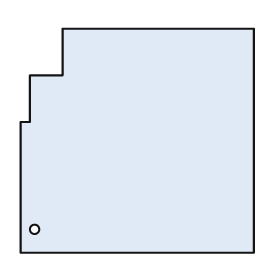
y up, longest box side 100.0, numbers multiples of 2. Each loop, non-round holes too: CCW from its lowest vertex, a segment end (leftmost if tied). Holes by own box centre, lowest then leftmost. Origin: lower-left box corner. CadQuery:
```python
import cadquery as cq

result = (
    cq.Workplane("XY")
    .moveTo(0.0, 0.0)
    .lineTo(100.0, 0.0)
    .lineTo(100.0, 96.0)
    .lineTo(18.0, 96.0)
    .lineTo(18.0, 76.0)
    .lineTo(4.0, 76.0)
    .lineTo(4.0, 56.0)
    .lineTo(0.0, 56.0)
    .close()
    .moveTo(6.0, 10.0)
    .circle(2.0)
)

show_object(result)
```